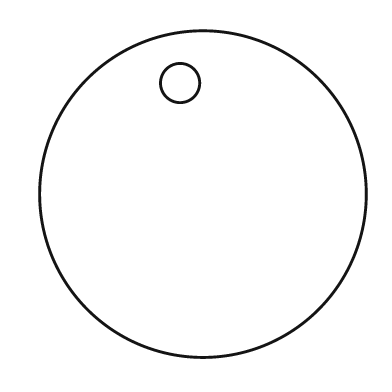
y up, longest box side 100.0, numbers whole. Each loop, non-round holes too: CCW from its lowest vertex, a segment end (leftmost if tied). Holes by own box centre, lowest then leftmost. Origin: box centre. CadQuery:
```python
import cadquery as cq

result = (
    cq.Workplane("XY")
    .moveTo(0.0, 0.0)
    .circle(50.0)
    .moveTo(-7.0, 34.0)
    .circle(6.0)
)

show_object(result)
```